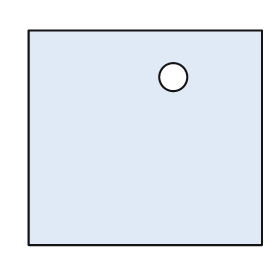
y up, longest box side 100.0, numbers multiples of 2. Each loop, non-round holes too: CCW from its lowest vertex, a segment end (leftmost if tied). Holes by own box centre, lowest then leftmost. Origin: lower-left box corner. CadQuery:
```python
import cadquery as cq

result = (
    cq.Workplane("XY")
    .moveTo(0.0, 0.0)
    .lineTo(100.0, 0.0)
    .lineTo(100.0, 92.0)
    .lineTo(0.0, 92.0)
    .close()
    .moveTo(62.0, 72.0)
    .circle(6.0)
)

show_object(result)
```